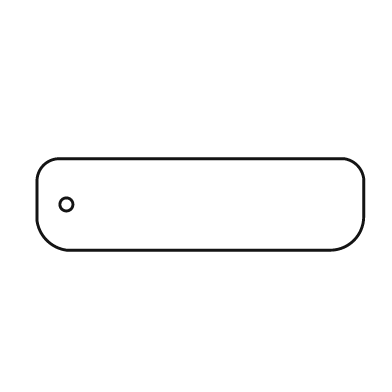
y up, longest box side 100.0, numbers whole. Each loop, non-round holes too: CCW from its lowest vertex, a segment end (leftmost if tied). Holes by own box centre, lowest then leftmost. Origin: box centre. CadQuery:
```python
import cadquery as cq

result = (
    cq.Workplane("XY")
    .moveTo(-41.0, -14.0)
    .lineTo(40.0, -14.0)
    .threePointArc((47.0, -11.0), (50.0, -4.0))
    .lineTo(50.0, 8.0)
    .threePointArc((48.0, 12.0), (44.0, 14.0))
    .lineTo(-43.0, 14.0)
    .threePointArc((-48.0, 12.0), (-50.0, 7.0))
    .lineTo(-50.0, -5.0)
    .threePointArc((-47.0, -11.0), (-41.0, -14.0))
    .close()
    .moveTo(-41.0, 0.0)
    .circle(2.0)
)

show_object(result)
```